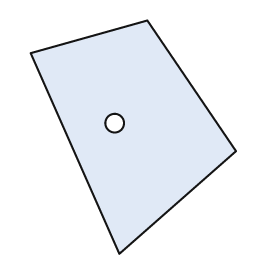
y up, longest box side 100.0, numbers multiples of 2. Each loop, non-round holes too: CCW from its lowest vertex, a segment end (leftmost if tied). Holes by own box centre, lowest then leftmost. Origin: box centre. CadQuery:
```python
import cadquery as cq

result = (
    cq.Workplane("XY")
    .moveTo(-6.0, -50.0)
    .lineTo(44.0, -6.0)
    .lineTo(6.0, 50.0)
    .lineTo(-44.0, 36.0)
    .close()
    .moveTo(-8.0, 6.0)
    .circle(4.0)
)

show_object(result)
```